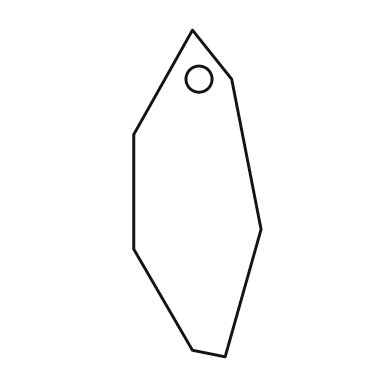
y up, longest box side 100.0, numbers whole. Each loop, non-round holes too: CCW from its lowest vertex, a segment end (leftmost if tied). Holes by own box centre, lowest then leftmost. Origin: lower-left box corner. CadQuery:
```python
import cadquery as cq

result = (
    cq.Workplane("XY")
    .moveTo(28.0, 0.0)
    .lineTo(39.0, 39.0)
    .lineTo(30.0, 85.0)
    .lineTo(18.0, 100.0)
    .lineTo(0.0, 68.0)
    .lineTo(0.0, 33.0)
    .lineTo(18.0, 2.0)
    .close()
    .moveTo(20.0, 85.0)
    .circle(4.0)
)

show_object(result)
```